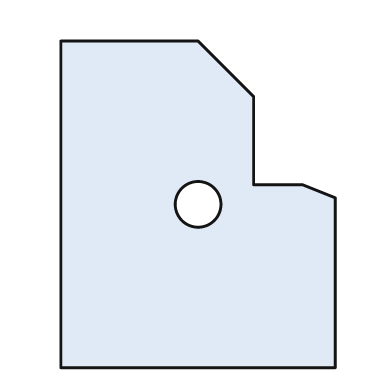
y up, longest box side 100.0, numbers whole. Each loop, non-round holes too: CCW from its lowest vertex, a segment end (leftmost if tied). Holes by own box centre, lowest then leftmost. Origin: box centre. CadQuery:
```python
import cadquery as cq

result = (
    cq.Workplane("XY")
    .moveTo(-42.0, -50.0)
    .lineTo(42.0, -50.0)
    .lineTo(42.0, 2.0)
    .lineTo(32.0, 6.0)
    .lineTo(17.0, 6.0)
    .lineTo(17.0, 33.0)
    .lineTo(0.0, 50.0)
    .lineTo(-42.0, 50.0)
    .close()
    .moveTo(0.0, 0.0)
    .circle(7.0)
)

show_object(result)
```